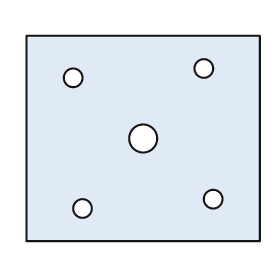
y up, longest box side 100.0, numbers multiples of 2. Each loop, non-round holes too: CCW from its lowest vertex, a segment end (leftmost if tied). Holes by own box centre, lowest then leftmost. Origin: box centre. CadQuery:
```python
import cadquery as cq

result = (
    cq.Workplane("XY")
    .moveTo(-50.0, -44.0)
    .lineTo(50.0, -44.0)
    .lineTo(50.0, 44.0)
    .lineTo(-50.0, 44.0)
    .close()
    .moveTo(-26.0, -30.0)
    .circle(4.0)
    .moveTo(30.0, -26.0)
    .circle(4.0)
    .moveTo(0.0, 0.0)
    .circle(6.0)
    .moveTo(-30.0, 26.0)
    .circle(4.0)
    .moveTo(26.0, 30.0)
    .circle(4.0)
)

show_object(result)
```